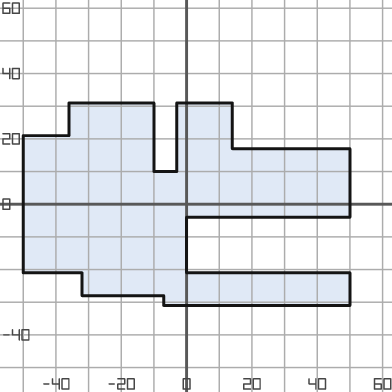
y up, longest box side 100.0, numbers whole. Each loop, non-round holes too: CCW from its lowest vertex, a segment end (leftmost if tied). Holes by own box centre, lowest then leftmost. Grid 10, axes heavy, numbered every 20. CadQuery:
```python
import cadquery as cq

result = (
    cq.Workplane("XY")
    .moveTo(-7.0, -31.0)
    .lineTo(50.0, -31.0)
    .lineTo(50.0, -21.0)
    .lineTo(0.0, -21.0)
    .lineTo(0.0, -4.0)
    .lineTo(50.0, -4.0)
    .lineTo(50.0, 17.0)
    .lineTo(14.0, 17.0)
    .lineTo(14.0, 31.0)
    .lineTo(-3.0, 31.0)
    .lineTo(-3.0, 10.0)
    .lineTo(-10.0, 10.0)
    .lineTo(-10.0, 31.0)
    .lineTo(-36.0, 31.0)
    .lineTo(-36.0, 21.0)
    .lineTo(-50.0, 21.0)
    .lineTo(-50.0, -21.0)
    .lineTo(-32.0, -21.0)
    .lineTo(-32.0, -28.0)
    .lineTo(-7.0, -28.0)
    .close()
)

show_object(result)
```